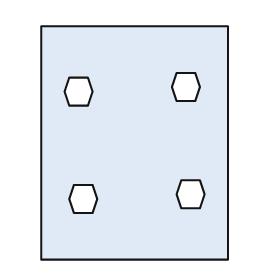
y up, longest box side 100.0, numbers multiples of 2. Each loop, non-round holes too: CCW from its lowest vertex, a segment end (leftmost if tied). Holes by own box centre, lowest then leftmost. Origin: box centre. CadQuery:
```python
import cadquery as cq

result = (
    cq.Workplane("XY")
    .moveTo(-40.0, -50.0)
    .lineTo(40.0, -50.0)
    .lineTo(40.0, 50.0)
    .lineTo(-40.0, 50.0)
    .close()
    .moveTo(-26.0, -30.0)
    .lineTo(-18.0, -30.0)
    .lineTo(-16.0, -24.0)
    .lineTo(-18.0, -18.0)
    .lineTo(-26.0, -18.0)
    .lineTo(-28.0, -24.0)
    .close()
    .moveTo(20.0, -28.0)
    .lineTo(28.0, -28.0)
    .lineTo(30.0, -22.0)
    .lineTo(28.0, -16.0)
    .lineTo(20.0, -16.0)
    .lineTo(18.0, -22.0)
    .close()
    .moveTo(-28.0, 16.0)
    .lineTo(-20.0, 16.0)
    .lineTo(-18.0, 22.0)
    .lineTo(-20.0, 28.0)
    .lineTo(-28.0, 28.0)
    .lineTo(-30.0, 22.0)
    .close()
    .moveTo(18.0, 18.0)
    .lineTo(26.0, 18.0)
    .lineTo(28.0, 24.0)
    .lineTo(26.0, 30.0)
    .lineTo(18.0, 30.0)
    .lineTo(16.0, 24.0)
    .close()
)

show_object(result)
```